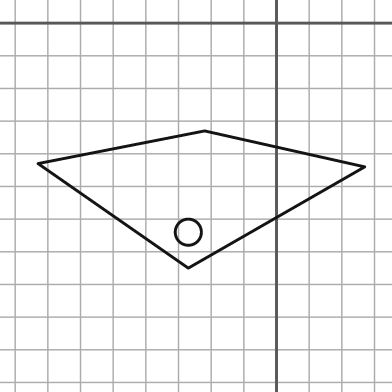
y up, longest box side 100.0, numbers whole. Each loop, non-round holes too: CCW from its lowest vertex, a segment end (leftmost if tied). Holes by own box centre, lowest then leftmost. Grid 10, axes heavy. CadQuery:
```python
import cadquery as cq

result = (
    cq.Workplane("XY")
    .moveTo(-27.0, -75.0)
    .lineTo(27.0, -44.0)
    .lineTo(-22.0, -33.0)
    .lineTo(-73.0, -43.0)
    .close()
    .moveTo(-27.0, -64.0)
    .circle(4.0)
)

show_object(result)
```